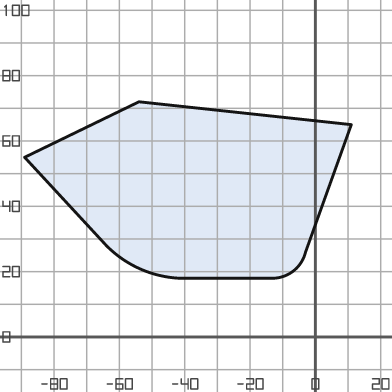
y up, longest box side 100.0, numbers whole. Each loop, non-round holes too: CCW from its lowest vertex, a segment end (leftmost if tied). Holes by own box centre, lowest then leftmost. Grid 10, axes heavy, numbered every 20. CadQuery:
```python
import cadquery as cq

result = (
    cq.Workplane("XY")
    .moveTo(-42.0, 18.0)
    .lineTo(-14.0, 18.0)
    .threePointArc((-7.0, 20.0), (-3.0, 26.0))
    .lineTo(11.0, 65.0)
    .lineTo(-54.0, 72.0)
    .lineTo(-89.0, 55.0)
    .lineTo(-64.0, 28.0)
    .threePointArc((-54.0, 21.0), (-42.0, 18.0))
    .close()
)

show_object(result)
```